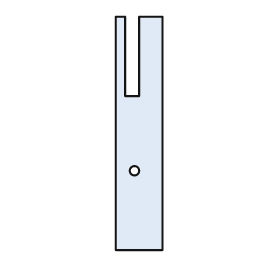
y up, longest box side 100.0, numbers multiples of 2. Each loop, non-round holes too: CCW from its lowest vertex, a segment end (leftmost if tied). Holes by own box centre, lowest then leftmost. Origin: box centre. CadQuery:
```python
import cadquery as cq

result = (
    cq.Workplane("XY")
    .moveTo(-10.0, -50.0)
    .lineTo(10.0, -50.0)
    .lineTo(10.0, 50.0)
    .lineTo(0.0, 50.0)
    .lineTo(0.0, 16.0)
    .lineTo(-6.0, 16.0)
    .lineTo(-6.0, 50.0)
    .lineTo(-10.0, 50.0)
    .close()
    .moveTo(-2.0, -16.0)
    .circle(2.0)
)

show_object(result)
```